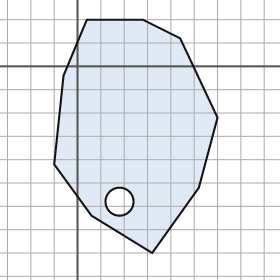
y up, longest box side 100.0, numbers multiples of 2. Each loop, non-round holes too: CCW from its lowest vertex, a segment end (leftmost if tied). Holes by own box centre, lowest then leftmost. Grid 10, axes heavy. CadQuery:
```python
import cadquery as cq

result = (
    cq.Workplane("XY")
    .moveTo(32.0, -80.0)
    .lineTo(52.0, -52.0)
    .lineTo(60.0, -22.0)
    .lineTo(44.0, 12.0)
    .lineTo(28.0, 20.0)
    .lineTo(4.0, 20.0)
    .lineTo(-6.0, -4.0)
    .lineTo(-10.0, -42.0)
    .lineTo(6.0, -64.0)
    .close()
    .moveTo(18.0, -58.0)
    .circle(6.0)
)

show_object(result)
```